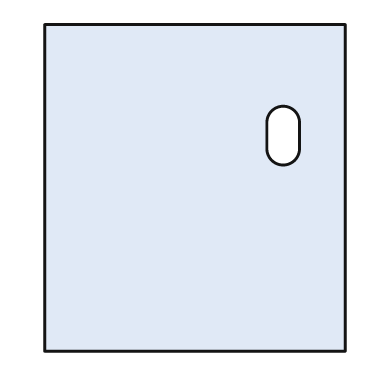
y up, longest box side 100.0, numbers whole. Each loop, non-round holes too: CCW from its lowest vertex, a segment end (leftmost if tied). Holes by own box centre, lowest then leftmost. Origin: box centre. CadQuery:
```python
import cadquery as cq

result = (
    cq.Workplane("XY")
    .moveTo(-46.0, -50.0)
    .lineTo(46.0, -50.0)
    .lineTo(46.0, 50.0)
    .lineTo(-46.0, 50.0)
    .close()
    .moveTo(22.0, 12.0)
    .threePointArc((27.0, 7.0), (32.0, 12.0))
    .lineTo(32.0, 20.0)
    .threePointArc((27.0, 25.0), (22.0, 20.0))
    .close()
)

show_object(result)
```